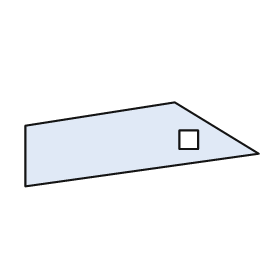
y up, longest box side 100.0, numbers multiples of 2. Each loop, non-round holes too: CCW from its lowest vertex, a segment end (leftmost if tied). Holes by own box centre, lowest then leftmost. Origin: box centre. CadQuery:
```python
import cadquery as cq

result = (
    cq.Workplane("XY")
    .moveTo(-50.0, -18.0)
    .lineTo(50.0, -4.0)
    .lineTo(14.0, 18.0)
    .lineTo(-50.0, 8.0)
    .close()
    .moveTo(16.0, -2.0)
    .lineTo(24.0, -2.0)
    .lineTo(24.0, 6.0)
    .lineTo(16.0, 6.0)
    .close()
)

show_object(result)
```